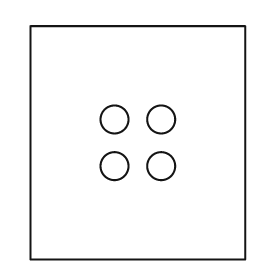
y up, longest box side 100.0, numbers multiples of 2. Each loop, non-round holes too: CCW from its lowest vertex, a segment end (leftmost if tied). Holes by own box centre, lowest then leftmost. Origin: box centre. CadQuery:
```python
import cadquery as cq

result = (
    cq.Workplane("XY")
    .moveTo(-46.0, -50.0)
    .lineTo(46.0, -50.0)
    .lineTo(46.0, 50.0)
    .lineTo(-46.0, 50.0)
    .close()
    .moveTo(-10.0, -10.0)
    .circle(6.0)
    .moveTo(10.0, -10.0)
    .circle(6.0)
    .moveTo(-10.0, 10.0)
    .circle(6.0)
    .moveTo(10.0, 10.0)
    .circle(6.0)
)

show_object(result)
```